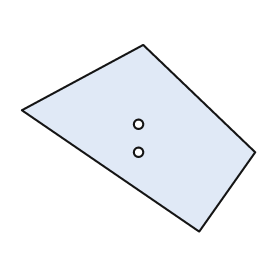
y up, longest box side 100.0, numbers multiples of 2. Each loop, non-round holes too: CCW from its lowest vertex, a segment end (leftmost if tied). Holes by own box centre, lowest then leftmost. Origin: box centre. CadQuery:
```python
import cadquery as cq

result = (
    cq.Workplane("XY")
    .moveTo(26.0, -40.0)
    .lineTo(50.0, -6.0)
    .lineTo(2.0, 40.0)
    .lineTo(-50.0, 12.0)
    .close()
    .moveTo(0.0, -6.0)
    .circle(2.0)
    .moveTo(0.0, 6.0)
    .circle(2.0)
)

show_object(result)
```